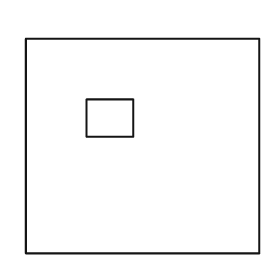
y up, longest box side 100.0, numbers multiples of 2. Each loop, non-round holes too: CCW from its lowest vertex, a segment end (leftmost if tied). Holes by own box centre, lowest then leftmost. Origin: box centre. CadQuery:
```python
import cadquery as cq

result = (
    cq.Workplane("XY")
    .moveTo(-50.0, -46.0)
    .lineTo(50.0, -46.0)
    .lineTo(50.0, 46.0)
    .lineTo(-50.0, 46.0)
    .close()
    .moveTo(-24.0, 4.0)
    .lineTo(-4.0, 4.0)
    .lineTo(-4.0, 20.0)
    .lineTo(-24.0, 20.0)
    .close()
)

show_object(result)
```